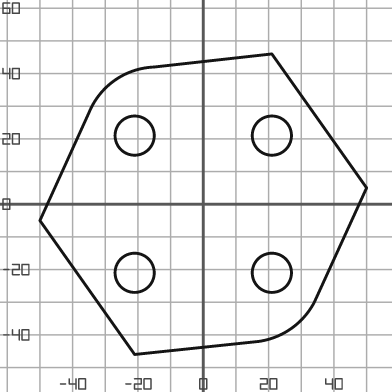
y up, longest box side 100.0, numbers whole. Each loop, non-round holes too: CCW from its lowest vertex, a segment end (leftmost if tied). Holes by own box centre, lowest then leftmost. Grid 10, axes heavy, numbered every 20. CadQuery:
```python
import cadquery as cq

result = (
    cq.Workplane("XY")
    .moveTo(-21.0, -46.0)
    .lineTo(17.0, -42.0)
    .threePointArc((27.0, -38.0), (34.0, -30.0))
    .lineTo(50.0, 5.0)
    .lineTo(21.0, 46.0)
    .lineTo(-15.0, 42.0)
    .threePointArc((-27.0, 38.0), (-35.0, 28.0))
    .lineTo(-50.0, -5.0)
    .close()
    .moveTo(-21.0, -21.0)
    .circle(6.0)
    .moveTo(21.0, -21.0)
    .circle(6.0)
    .moveTo(-21.0, 21.0)
    .circle(6.0)
    .moveTo(21.0, 21.0)
    .circle(6.0)
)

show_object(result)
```